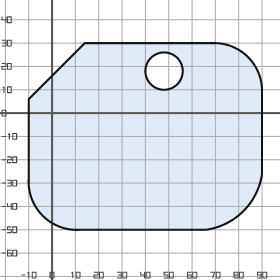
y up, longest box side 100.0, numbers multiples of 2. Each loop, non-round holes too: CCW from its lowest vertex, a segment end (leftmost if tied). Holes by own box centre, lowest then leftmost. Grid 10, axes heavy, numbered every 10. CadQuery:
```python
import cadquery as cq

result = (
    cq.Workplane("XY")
    .moveTo(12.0, -50.0)
    .lineTo(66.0, -50.0)
    .threePointArc((82.0, -42.0), (90.0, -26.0))
    .lineTo(90.0, 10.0)
    .threePointArc((84.0, 24.0), (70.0, 30.0))
    .lineTo(14.0, 30.0)
    .lineTo(-10.0, 6.0)
    .lineTo(-10.0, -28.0)
    .threePointArc((-4.0, -44.0), (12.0, -50.0))
    .close()
    .moveTo(48.0, 18.0)
    .circle(8.0)
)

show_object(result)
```